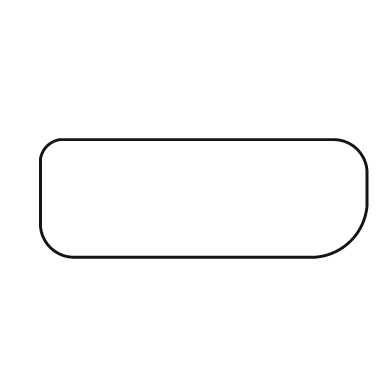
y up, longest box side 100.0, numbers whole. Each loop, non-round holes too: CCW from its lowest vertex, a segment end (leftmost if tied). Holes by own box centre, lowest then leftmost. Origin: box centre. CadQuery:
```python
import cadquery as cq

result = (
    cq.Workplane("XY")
    .moveTo(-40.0, -18.0)
    .lineTo(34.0, -18.0)
    .threePointArc((45.0, -13.0), (50.0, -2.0))
    .lineTo(50.0, 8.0)
    .threePointArc((47.0, 15.0), (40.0, 18.0))
    .lineTo(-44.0, 18.0)
    .threePointArc((-48.0, 16.0), (-50.0, 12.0))
    .lineTo(-50.0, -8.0)
    .threePointArc((-47.0, -15.0), (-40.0, -18.0))
    .close()
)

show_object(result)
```